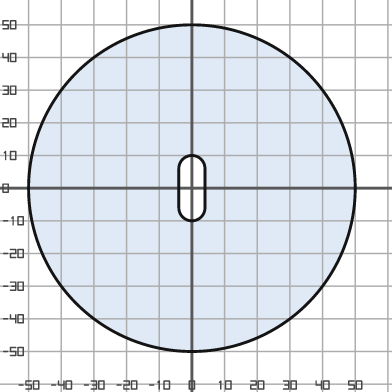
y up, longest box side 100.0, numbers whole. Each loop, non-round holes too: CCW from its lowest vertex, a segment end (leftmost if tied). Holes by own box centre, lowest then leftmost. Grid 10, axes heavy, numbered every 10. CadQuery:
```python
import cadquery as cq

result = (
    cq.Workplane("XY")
    .moveTo(0.0, 0.0)
    .circle(50.0)
    .moveTo(-4.0, -6.0)
    .threePointArc((0.0, -10.0), (4.0, -6.0))
    .lineTo(4.0, 6.0)
    .threePointArc((0.0, 10.0), (-4.0, 6.0))
    .close()
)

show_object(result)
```